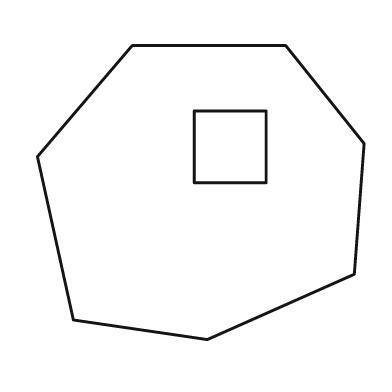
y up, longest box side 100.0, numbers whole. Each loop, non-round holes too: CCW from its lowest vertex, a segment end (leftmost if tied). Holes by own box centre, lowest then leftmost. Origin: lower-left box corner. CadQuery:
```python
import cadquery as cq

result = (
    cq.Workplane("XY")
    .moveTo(52.0, 0.0)
    .lineTo(97.0, 20.0)
    .lineTo(100.0, 60.0)
    .lineTo(76.0, 90.0)
    .lineTo(29.0, 90.0)
    .lineTo(0.0, 56.0)
    .lineTo(11.0, 6.0)
    .close()
    .moveTo(48.0, 48.0)
    .lineTo(70.0, 48.0)
    .lineTo(70.0, 70.0)
    .lineTo(48.0, 70.0)
    .close()
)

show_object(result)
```